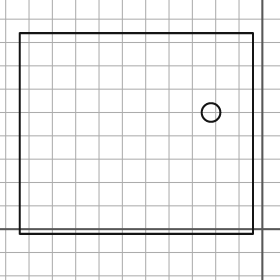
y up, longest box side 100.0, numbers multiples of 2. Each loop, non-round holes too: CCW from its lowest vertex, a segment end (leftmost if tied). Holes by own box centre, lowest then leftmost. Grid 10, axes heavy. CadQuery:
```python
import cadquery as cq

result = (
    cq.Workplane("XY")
    .moveTo(-104.0, -2.0)
    .lineTo(-4.0, -2.0)
    .lineTo(-4.0, 84.0)
    .lineTo(-104.0, 84.0)
    .close()
    .moveTo(-22.0, 50.0)
    .circle(4.0)
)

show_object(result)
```